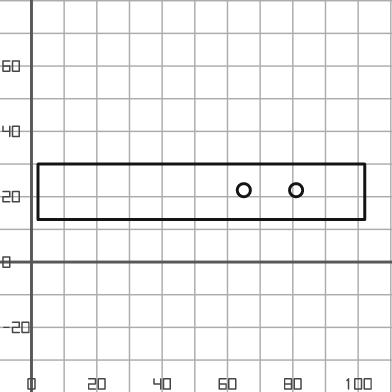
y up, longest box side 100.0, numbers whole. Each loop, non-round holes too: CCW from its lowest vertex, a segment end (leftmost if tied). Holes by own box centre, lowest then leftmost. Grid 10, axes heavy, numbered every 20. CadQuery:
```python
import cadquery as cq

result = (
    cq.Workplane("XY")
    .moveTo(2.0, 13.0)
    .lineTo(102.0, 13.0)
    .lineTo(102.0, 30.0)
    .lineTo(2.0, 30.0)
    .close()
    .moveTo(65.0, 22.0)
    .circle(2.0)
    .moveTo(81.0, 22.0)
    .circle(2.0)
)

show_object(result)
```